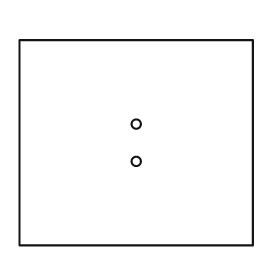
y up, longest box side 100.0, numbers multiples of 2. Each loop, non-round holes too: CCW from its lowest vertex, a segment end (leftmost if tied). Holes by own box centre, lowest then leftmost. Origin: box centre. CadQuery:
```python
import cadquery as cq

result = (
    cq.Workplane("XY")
    .moveTo(-50.0, -44.0)
    .lineTo(50.0, -44.0)
    .lineTo(50.0, 44.0)
    .lineTo(-50.0, 44.0)
    .close()
    .moveTo(0.0, -8.0)
    .circle(2.0)
    .moveTo(0.0, 8.0)
    .circle(2.0)
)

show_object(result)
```